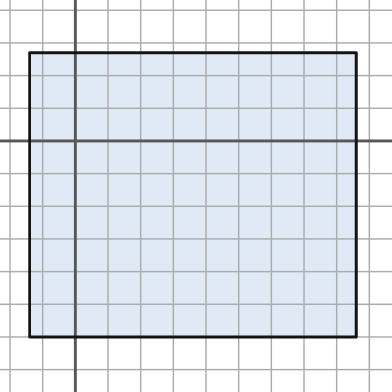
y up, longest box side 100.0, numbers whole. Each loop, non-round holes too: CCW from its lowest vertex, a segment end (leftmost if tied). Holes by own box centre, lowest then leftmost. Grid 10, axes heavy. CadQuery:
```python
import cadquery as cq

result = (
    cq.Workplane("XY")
    .moveTo(-14.0, -60.0)
    .lineTo(86.0, -60.0)
    .lineTo(86.0, 27.0)
    .lineTo(-14.0, 27.0)
    .close()
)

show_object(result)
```